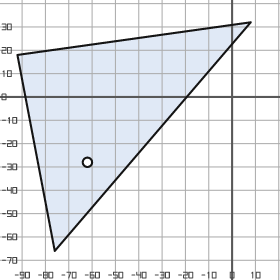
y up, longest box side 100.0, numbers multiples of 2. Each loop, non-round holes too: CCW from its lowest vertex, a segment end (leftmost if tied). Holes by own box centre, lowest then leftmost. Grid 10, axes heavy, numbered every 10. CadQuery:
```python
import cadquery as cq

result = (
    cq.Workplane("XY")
    .moveTo(-76.0, -66.0)
    .lineTo(8.0, 32.0)
    .lineTo(-92.0, 18.0)
    .close()
    .moveTo(-62.0, -28.0)
    .circle(2.0)
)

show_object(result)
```